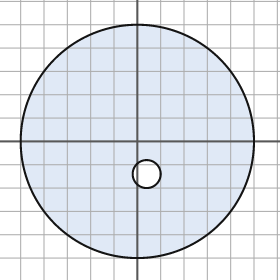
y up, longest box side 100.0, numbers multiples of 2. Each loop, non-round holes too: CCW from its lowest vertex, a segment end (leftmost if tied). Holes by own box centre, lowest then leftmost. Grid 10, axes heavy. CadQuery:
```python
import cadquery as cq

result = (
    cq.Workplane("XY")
    .moveTo(0.0, 0.0)
    .circle(50.0)
    .moveTo(4.0, -14.0)
    .circle(6.0)
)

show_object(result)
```